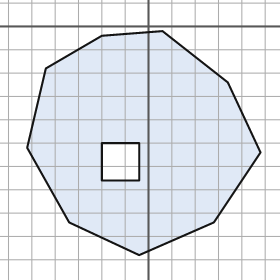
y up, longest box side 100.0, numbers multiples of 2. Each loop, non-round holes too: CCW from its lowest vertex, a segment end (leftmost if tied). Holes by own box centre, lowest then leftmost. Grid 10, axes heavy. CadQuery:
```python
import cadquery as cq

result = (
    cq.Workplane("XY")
    .moveTo(-4.0, -98.0)
    .lineTo(28.0, -84.0)
    .lineTo(48.0, -54.0)
    .lineTo(34.0, -24.0)
    .lineTo(6.0, -2.0)
    .lineTo(-20.0, -4.0)
    .lineTo(-44.0, -18.0)
    .lineTo(-52.0, -52.0)
    .lineTo(-34.0, -84.0)
    .close()
    .moveTo(-20.0, -66.0)
    .lineTo(-4.0, -66.0)
    .lineTo(-4.0, -50.0)
    .lineTo(-20.0, -50.0)
    .close()
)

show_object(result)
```